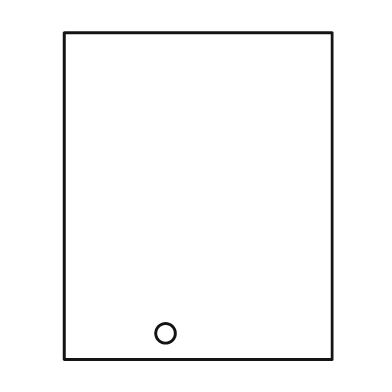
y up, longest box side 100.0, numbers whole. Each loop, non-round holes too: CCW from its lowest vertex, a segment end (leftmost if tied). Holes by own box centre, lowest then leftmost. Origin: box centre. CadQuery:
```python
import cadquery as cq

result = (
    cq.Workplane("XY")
    .moveTo(-41.0, -50.0)
    .lineTo(41.0, -50.0)
    .lineTo(41.0, 50.0)
    .lineTo(-41.0, 50.0)
    .close()
    .moveTo(-10.0, -42.0)
    .circle(3.0)
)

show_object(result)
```